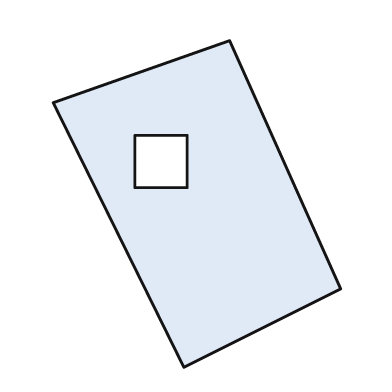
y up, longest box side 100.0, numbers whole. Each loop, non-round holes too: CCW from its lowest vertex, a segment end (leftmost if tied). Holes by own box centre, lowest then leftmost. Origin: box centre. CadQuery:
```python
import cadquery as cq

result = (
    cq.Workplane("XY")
    .moveTo(-4.0, -50.0)
    .lineTo(44.0, -26.0)
    .lineTo(10.0, 50.0)
    .lineTo(-44.0, 31.0)
    .close()
    .moveTo(-19.0, 5.0)
    .lineTo(-3.0, 5.0)
    .lineTo(-3.0, 21.0)
    .lineTo(-19.0, 21.0)
    .close()
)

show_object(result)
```